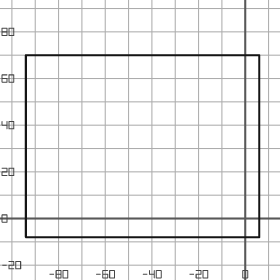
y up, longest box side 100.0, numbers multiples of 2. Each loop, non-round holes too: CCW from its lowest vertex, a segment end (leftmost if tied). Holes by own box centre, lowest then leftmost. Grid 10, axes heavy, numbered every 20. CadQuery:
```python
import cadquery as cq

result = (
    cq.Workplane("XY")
    .moveTo(-94.0, -8.0)
    .lineTo(6.0, -8.0)
    .lineTo(6.0, 70.0)
    .lineTo(-94.0, 70.0)
    .close()
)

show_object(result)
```